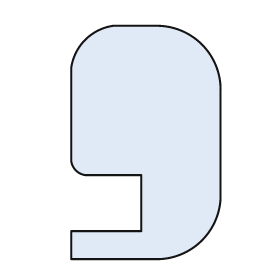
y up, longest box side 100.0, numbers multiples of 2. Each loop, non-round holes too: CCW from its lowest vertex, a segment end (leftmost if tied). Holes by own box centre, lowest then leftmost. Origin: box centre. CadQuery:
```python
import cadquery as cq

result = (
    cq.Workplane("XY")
    .moveTo(-32.0, -50.0)
    .lineTo(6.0, -50.0)
    .threePointArc((24.0, -42.0), (32.0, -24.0))
    .lineTo(32.0, 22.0)
    .threePointArc((24.0, 42.0), (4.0, 50.0))
    .lineTo(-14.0, 50.0)
    .threePointArc((-26.0, 44.0), (-32.0, 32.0))
    .lineTo(-32.0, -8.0)
    .threePointArc((-30.0, -12.0), (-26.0, -14.0))
    .lineTo(-2.0, -14.0)
    .lineTo(-2.0, -38.0)
    .lineTo(-32.0, -38.0)
    .close()
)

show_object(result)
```